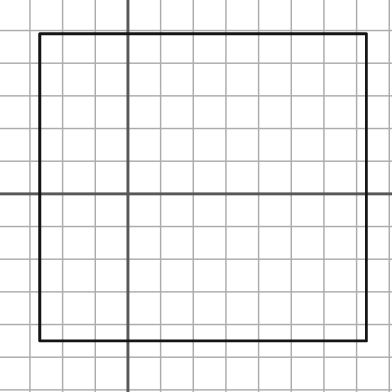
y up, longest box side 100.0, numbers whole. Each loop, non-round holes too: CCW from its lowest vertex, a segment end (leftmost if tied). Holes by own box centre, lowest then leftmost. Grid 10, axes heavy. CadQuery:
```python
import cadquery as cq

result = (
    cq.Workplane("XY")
    .moveTo(-27.0, -45.0)
    .lineTo(73.0, -45.0)
    .lineTo(73.0, 49.0)
    .lineTo(-27.0, 49.0)
    .close()
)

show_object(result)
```